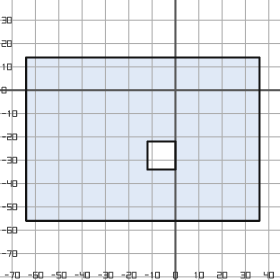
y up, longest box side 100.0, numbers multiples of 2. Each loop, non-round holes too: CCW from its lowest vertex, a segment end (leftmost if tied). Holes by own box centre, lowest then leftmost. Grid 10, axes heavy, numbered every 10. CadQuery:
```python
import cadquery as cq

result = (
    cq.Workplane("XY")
    .moveTo(-64.0, -56.0)
    .lineTo(36.0, -56.0)
    .lineTo(36.0, 14.0)
    .lineTo(-64.0, 14.0)
    .close()
    .moveTo(-12.0, -34.0)
    .lineTo(0.0, -34.0)
    .lineTo(0.0, -22.0)
    .lineTo(-12.0, -22.0)
    .close()
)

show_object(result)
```